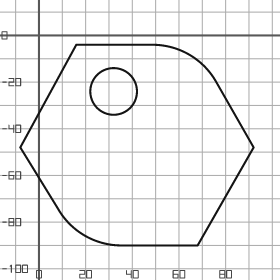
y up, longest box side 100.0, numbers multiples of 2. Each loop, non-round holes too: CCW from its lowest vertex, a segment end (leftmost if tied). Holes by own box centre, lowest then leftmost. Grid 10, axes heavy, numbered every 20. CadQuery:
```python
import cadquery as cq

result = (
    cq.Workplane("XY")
    .moveTo(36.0, -90.0)
    .lineTo(68.0, -90.0)
    .lineTo(92.0, -48.0)
    .lineTo(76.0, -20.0)
    .threePointArc((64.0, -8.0), (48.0, -4.0))
    .lineTo(16.0, -4.0)
    .lineTo(-8.0, -48.0)
    .lineTo(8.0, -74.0)
    .threePointArc((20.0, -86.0), (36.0, -90.0))
    .close()
    .moveTo(32.0, -24.0)
    .circle(10.0)
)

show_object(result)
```